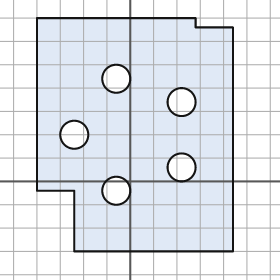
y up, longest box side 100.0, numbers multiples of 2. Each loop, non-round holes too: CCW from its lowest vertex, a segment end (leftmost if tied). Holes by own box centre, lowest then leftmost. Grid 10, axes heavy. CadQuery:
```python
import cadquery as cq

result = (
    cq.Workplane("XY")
    .moveTo(-24.0, -30.0)
    .lineTo(44.0, -30.0)
    .lineTo(44.0, 66.0)
    .lineTo(28.0, 66.0)
    .lineTo(28.0, 70.0)
    .lineTo(-40.0, 70.0)
    .lineTo(-40.0, -4.0)
    .lineTo(-24.0, -4.0)
    .close()
    .moveTo(-6.0, -4.0)
    .circle(6.0)
    .moveTo(22.0, 6.0)
    .circle(6.0)
    .moveTo(-24.0, 20.0)
    .circle(6.0)
    .moveTo(22.0, 34.0)
    .circle(6.0)
    .moveTo(-6.0, 44.0)
    .circle(6.0)
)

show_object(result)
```